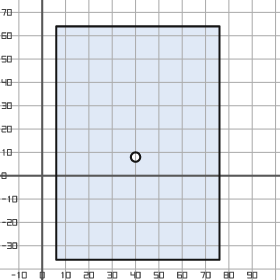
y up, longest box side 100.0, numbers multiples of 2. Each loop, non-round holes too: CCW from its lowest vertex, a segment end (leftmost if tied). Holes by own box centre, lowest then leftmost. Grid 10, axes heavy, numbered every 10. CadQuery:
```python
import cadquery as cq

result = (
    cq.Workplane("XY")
    .moveTo(6.0, -36.0)
    .lineTo(76.0, -36.0)
    .lineTo(76.0, 64.0)
    .lineTo(6.0, 64.0)
    .close()
    .moveTo(40.0, 8.0)
    .circle(2.0)
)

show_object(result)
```